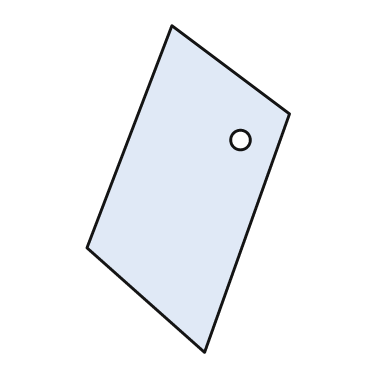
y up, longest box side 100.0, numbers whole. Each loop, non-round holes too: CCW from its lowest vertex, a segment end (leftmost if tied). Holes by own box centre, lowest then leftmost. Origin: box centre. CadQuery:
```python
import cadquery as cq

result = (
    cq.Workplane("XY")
    .moveTo(5.0, -50.0)
    .lineTo(31.0, 23.0)
    .lineTo(-5.0, 50.0)
    .lineTo(-31.0, -18.0)
    .close()
    .moveTo(16.0, 15.0)
    .circle(3.0)
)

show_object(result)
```